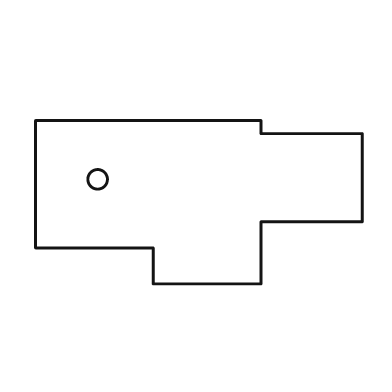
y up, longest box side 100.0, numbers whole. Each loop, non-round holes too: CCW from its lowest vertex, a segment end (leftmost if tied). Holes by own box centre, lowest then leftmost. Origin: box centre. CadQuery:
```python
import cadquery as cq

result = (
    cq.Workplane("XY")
    .moveTo(-14.0, -25.0)
    .lineTo(19.0, -25.0)
    .lineTo(19.0, -6.0)
    .lineTo(50.0, -6.0)
    .lineTo(50.0, 21.0)
    .lineTo(19.0, 21.0)
    .lineTo(19.0, 25.0)
    .lineTo(-50.0, 25.0)
    .lineTo(-50.0, -14.0)
    .lineTo(-14.0, -14.0)
    .close()
    .moveTo(-31.0, 7.0)
    .circle(3.0)
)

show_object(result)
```